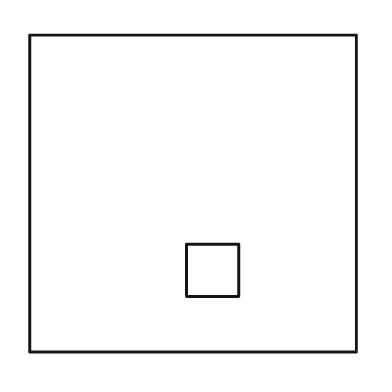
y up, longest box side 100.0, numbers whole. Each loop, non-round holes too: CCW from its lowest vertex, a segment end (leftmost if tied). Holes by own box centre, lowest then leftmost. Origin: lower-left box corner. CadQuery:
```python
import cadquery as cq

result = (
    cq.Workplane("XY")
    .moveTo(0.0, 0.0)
    .lineTo(100.0, 0.0)
    .lineTo(100.0, 97.0)
    .lineTo(0.0, 97.0)
    .close()
    .moveTo(48.0, 17.0)
    .lineTo(64.0, 17.0)
    .lineTo(64.0, 33.0)
    .lineTo(48.0, 33.0)
    .close()
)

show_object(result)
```